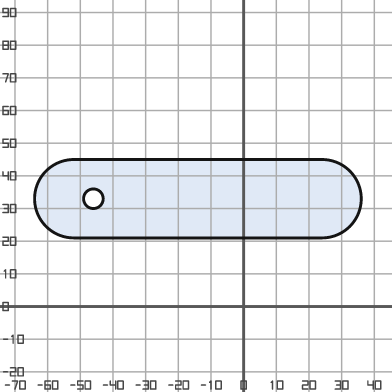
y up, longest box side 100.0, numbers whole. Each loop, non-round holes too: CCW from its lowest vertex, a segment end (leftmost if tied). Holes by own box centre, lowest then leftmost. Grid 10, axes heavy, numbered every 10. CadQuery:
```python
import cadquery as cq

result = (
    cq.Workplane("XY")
    .moveTo(-52.0, 21.0)
    .lineTo(24.0, 21.0)
    .threePointArc((36.0, 33.0), (24.0, 45.0))
    .lineTo(-52.0, 45.0)
    .threePointArc((-64.0, 33.0), (-52.0, 21.0))
    .close()
    .moveTo(-46.0, 33.0)
    .circle(3.0)
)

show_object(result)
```